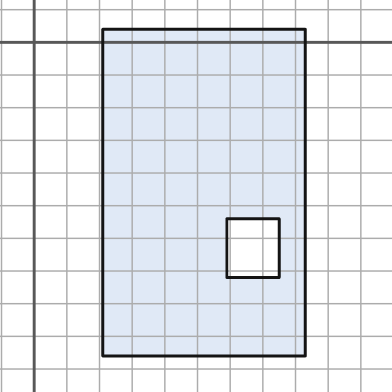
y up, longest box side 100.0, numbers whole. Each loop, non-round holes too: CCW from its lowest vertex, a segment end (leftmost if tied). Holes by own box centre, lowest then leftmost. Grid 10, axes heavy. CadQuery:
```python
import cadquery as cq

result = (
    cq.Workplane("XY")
    .moveTo(21.0, -96.0)
    .lineTo(83.0, -96.0)
    .lineTo(83.0, 4.0)
    .lineTo(21.0, 4.0)
    .close()
    .moveTo(59.0, -72.0)
    .lineTo(75.0, -72.0)
    .lineTo(75.0, -54.0)
    .lineTo(59.0, -54.0)
    .close()
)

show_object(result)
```